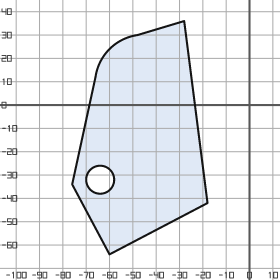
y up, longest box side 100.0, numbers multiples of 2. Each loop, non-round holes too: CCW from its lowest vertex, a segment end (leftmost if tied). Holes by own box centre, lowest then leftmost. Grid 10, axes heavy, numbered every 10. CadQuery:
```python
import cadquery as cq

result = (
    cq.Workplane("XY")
    .moveTo(-60.0, -64.0)
    .lineTo(-18.0, -42.0)
    .lineTo(-28.0, 36.0)
    .lineTo(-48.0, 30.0)
    .threePointArc((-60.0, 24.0), (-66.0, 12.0))
    .lineTo(-76.0, -34.0)
    .close()
    .moveTo(-64.0, -32.0)
    .circle(6.0)
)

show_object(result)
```